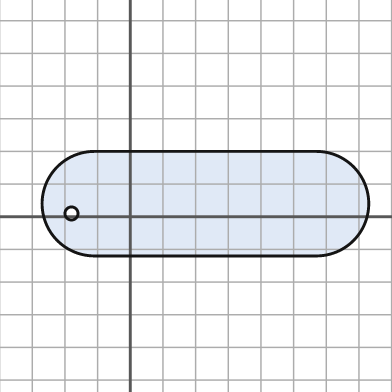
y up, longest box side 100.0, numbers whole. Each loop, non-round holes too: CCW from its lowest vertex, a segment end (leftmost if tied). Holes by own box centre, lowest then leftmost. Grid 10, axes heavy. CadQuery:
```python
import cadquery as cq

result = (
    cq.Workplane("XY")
    .moveTo(-11.0, -12.0)
    .lineTo(57.0, -12.0)
    .threePointArc((73.0, 4.0), (57.0, 20.0))
    .lineTo(-11.0, 20.0)
    .threePointArc((-27.0, 4.0), (-11.0, -12.0))
    .close()
    .moveTo(-18.0, 1.0)
    .circle(2.0)
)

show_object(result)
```